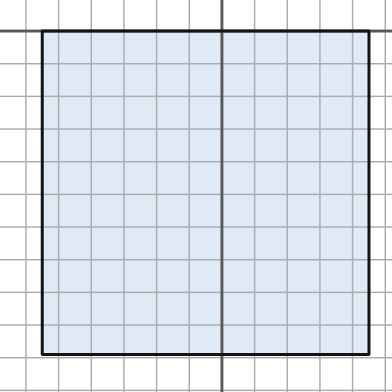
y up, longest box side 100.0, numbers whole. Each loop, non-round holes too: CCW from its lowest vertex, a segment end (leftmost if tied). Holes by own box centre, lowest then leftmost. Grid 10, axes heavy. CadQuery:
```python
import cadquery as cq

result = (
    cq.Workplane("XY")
    .moveTo(-55.0, -99.0)
    .lineTo(45.0, -99.0)
    .lineTo(45.0, 0.0)
    .lineTo(-55.0, 0.0)
    .close()
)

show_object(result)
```